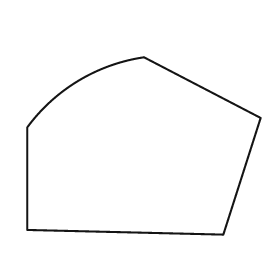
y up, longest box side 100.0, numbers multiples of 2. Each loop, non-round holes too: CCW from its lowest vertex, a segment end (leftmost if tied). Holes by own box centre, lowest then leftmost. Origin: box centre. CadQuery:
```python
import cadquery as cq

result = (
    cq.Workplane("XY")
    .moveTo(34.0, -38.0)
    .lineTo(50.0, 12.0)
    .lineTo(0.0, 38.0)
    .threePointArc((-28.0, 28.0), (-50.0, 8.0))
    .lineTo(-50.0, -36.0)
    .close()
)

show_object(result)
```